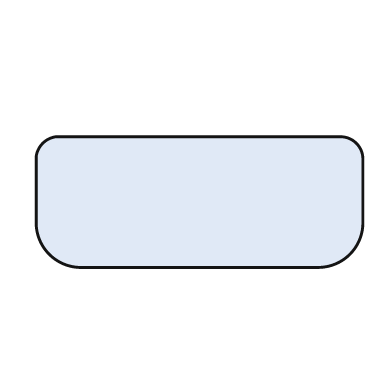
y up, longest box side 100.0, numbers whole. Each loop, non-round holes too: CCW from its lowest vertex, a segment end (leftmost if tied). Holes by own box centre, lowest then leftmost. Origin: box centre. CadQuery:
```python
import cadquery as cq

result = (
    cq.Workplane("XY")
    .moveTo(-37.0, -20.0)
    .lineTo(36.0, -20.0)
    .threePointArc((46.0, -16.0), (50.0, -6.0))
    .lineTo(50.0, 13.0)
    .threePointArc((48.0, 18.0), (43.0, 20.0))
    .lineTo(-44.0, 20.0)
    .threePointArc((-48.0, 18.0), (-50.0, 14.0))
    .lineTo(-50.0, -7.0)
    .threePointArc((-46.0, -16.0), (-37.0, -20.0))
    .close()
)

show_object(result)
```